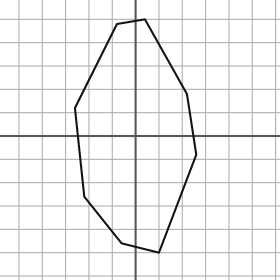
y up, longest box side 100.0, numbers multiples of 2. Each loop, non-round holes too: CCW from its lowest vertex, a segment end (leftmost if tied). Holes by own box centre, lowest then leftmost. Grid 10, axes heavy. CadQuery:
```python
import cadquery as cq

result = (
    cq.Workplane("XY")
    .moveTo(10.0, -50.0)
    .lineTo(26.0, -8.0)
    .lineTo(22.0, 18.0)
    .lineTo(4.0, 50.0)
    .lineTo(-8.0, 48.0)
    .lineTo(-26.0, 12.0)
    .lineTo(-22.0, -26.0)
    .lineTo(-6.0, -46.0)
    .close()
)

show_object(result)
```